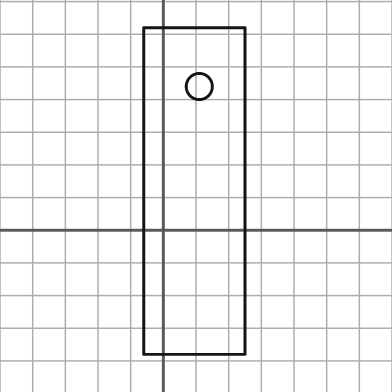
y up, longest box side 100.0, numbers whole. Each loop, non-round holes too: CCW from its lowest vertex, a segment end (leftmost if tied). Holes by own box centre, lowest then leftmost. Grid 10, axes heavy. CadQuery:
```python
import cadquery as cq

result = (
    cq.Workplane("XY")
    .moveTo(-6.0, -38.0)
    .lineTo(25.0, -38.0)
    .lineTo(25.0, 62.0)
    .lineTo(-6.0, 62.0)
    .close()
    .moveTo(11.0, 44.0)
    .circle(4.0)
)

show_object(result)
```